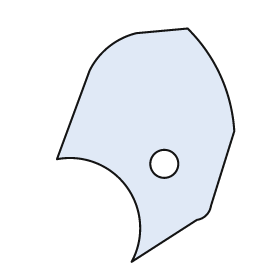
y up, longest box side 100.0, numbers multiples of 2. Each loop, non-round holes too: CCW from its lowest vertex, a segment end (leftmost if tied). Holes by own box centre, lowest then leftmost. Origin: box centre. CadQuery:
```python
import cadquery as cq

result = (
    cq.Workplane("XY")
    .moveTo(-6.0, -50.0)
    .lineTo(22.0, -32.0)
    .threePointArc((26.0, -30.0), (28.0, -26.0))
    .lineTo(38.0, 6.0)
    .threePointArc((32.0, 30.0), (18.0, 50.0))
    .lineTo(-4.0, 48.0)
    .threePointArc((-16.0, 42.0), (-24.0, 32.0))
    .lineTo(-38.0, -6.0)
    .threePointArc((-8.0, -18.0), (-6.0, -50.0))
    .close()
    .moveTo(8.0, -8.0)
    .circle(6.0)
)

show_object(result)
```